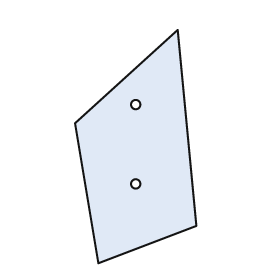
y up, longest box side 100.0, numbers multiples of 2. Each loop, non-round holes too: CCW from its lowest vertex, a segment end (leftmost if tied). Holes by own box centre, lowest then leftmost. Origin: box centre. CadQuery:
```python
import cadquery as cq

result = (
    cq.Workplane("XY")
    .moveTo(-16.0, -50.0)
    .lineTo(26.0, -34.0)
    .lineTo(18.0, 50.0)
    .lineTo(-26.0, 10.0)
    .close()
    .moveTo(0.0, -16.0)
    .circle(2.0)
    .moveTo(0.0, 18.0)
    .circle(2.0)
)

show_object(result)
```